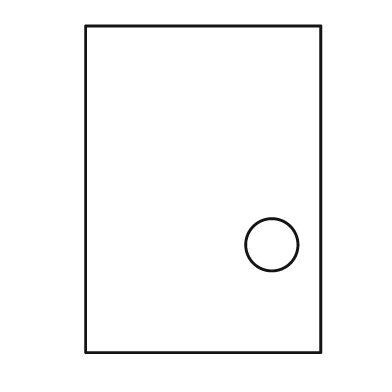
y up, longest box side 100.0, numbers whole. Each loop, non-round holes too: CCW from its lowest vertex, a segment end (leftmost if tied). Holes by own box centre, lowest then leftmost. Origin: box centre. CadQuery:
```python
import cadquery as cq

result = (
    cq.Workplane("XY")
    .moveTo(-36.0, -50.0)
    .lineTo(36.0, -50.0)
    .lineTo(36.0, 50.0)
    .lineTo(-36.0, 50.0)
    .close()
    .moveTo(21.0, -17.0)
    .circle(8.0)
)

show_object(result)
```